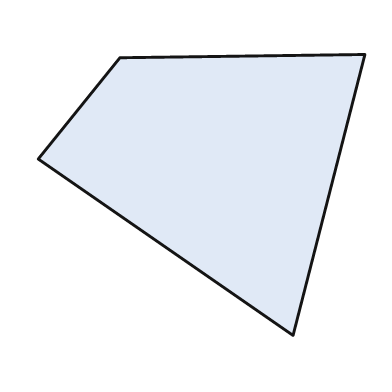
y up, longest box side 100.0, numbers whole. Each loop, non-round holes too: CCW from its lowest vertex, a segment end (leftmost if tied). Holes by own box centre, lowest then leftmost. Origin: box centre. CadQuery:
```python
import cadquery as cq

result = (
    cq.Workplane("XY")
    .moveTo(28.0, -43.0)
    .lineTo(50.0, 43.0)
    .lineTo(-25.0, 42.0)
    .lineTo(-50.0, 11.0)
    .close()
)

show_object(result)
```